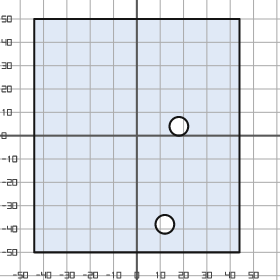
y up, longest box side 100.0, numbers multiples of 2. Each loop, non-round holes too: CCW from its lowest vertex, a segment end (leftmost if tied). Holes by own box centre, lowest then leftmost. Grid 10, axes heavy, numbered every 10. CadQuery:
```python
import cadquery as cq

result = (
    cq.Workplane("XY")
    .moveTo(-44.0, -50.0)
    .lineTo(44.0, -50.0)
    .lineTo(44.0, 50.0)
    .lineTo(-44.0, 50.0)
    .close()
    .moveTo(12.0, -38.0)
    .circle(4.0)
    .moveTo(18.0, 4.0)
    .circle(4.0)
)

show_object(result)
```